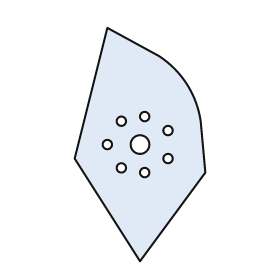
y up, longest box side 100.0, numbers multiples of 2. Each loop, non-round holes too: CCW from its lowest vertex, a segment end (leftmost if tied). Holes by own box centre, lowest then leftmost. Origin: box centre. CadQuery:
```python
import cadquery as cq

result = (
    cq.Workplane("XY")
    .moveTo(0.0, -50.0)
    .lineTo(28.0, -12.0)
    .lineTo(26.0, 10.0)
    .threePointArc((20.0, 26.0), (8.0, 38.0))
    .lineTo(-14.0, 50.0)
    .lineTo(-28.0, -6.0)
    .close()
    .moveTo(2.0, -12.0)
    .circle(2.0)
    .moveTo(-8.0, -10.0)
    .circle(2.0)
    .moveTo(12.0, -6.0)
    .circle(2.0)
    .moveTo(-14.0, 0.0)
    .circle(2.0)
    .moveTo(0.0, 0.0)
    .circle(4.0)
    .moveTo(12.0, 6.0)
    .circle(2.0)
    .moveTo(-8.0, 10.0)
    .circle(2.0)
    .moveTo(2.0, 12.0)
    .circle(2.0)
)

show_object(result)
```